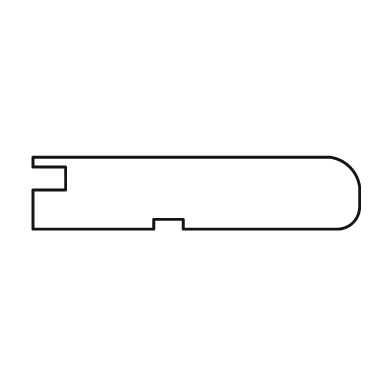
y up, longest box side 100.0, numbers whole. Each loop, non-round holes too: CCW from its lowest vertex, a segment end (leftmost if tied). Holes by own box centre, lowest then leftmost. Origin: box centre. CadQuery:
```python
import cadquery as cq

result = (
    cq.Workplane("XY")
    .moveTo(-50.0, -11.0)
    .lineTo(-13.0, -11.0)
    .lineTo(-13.0, -8.0)
    .lineTo(-4.0, -8.0)
    .lineTo(-4.0, -11.0)
    .lineTo(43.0, -11.0)
    .threePointArc((48.0, -9.0), (50.0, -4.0))
    .lineTo(50.0, 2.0)
    .threePointArc((47.0, 8.0), (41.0, 11.0))
    .lineTo(-50.0, 11.0)
    .lineTo(-50.0, 8.0)
    .lineTo(-40.0, 8.0)
    .lineTo(-40.0, 1.0)
    .lineTo(-50.0, 1.0)
    .close()
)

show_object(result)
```